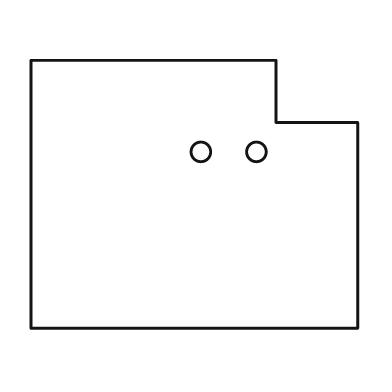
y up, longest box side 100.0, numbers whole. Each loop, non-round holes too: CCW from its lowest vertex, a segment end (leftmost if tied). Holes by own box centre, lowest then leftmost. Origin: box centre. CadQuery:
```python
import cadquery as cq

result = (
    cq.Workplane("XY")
    .moveTo(-50.0, -41.0)
    .lineTo(50.0, -41.0)
    .lineTo(50.0, 22.0)
    .lineTo(25.0, 22.0)
    .lineTo(25.0, 41.0)
    .lineTo(-50.0, 41.0)
    .close()
    .moveTo(2.0, 13.0)
    .circle(3.0)
    .moveTo(19.0, 13.0)
    .circle(3.0)
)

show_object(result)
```